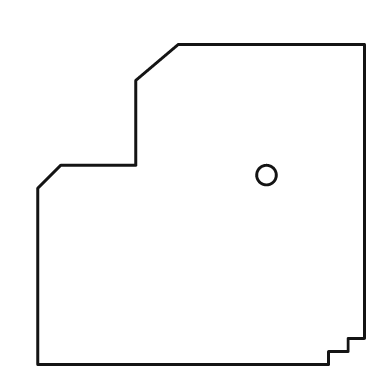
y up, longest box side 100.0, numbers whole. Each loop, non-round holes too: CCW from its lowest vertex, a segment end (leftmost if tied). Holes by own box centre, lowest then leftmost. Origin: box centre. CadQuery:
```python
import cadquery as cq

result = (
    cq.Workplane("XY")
    .moveTo(-50.0, -49.0)
    .lineTo(39.0, -49.0)
    .lineTo(39.0, -45.0)
    .lineTo(45.0, -45.0)
    .lineTo(45.0, -41.0)
    .lineTo(50.0, -41.0)
    .lineTo(50.0, 49.0)
    .lineTo(-7.0, 49.0)
    .lineTo(-20.0, 38.0)
    .lineTo(-20.0, 12.0)
    .lineTo(-43.0, 12.0)
    .lineTo(-50.0, 5.0)
    .close()
    .moveTo(20.0, 9.0)
    .circle(3.0)
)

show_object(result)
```